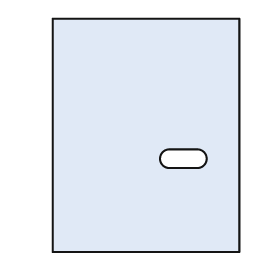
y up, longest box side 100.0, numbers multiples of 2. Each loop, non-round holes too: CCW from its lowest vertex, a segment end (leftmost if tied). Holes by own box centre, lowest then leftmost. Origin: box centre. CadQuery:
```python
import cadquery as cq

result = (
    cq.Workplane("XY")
    .moveTo(-40.0, -50.0)
    .lineTo(40.0, -50.0)
    .lineTo(40.0, 50.0)
    .lineTo(-40.0, 50.0)
    .close()
    .moveTo(10.0, -14.0)
    .lineTo(22.0, -14.0)
    .threePointArc((26.0, -10.0), (22.0, -6.0))
    .lineTo(10.0, -6.0)
    .threePointArc((6.0, -10.0), (10.0, -14.0))
    .close()
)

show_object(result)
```